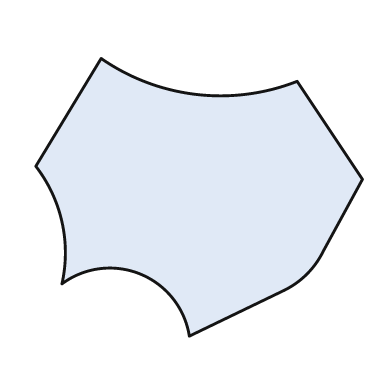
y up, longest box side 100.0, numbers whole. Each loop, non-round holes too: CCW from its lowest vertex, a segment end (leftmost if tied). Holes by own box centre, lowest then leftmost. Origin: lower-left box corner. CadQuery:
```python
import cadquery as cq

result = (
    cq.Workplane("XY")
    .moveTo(47.0, 0.0)
    .lineTo(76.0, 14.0)
    .threePointArc((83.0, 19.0), (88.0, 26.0))
    .lineTo(100.0, 48.0)
    .lineTo(80.0, 78.0)
    .threePointArc((49.0, 74.0), (20.0, 85.0))
    .lineTo(0.0, 52.0)
    .threePointArc((8.0, 35.0), (8.0, 16.0))
    .threePointArc((32.0, 19.0), (47.0, 0.0))
    .close()
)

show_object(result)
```